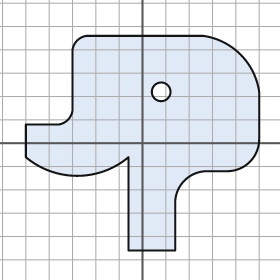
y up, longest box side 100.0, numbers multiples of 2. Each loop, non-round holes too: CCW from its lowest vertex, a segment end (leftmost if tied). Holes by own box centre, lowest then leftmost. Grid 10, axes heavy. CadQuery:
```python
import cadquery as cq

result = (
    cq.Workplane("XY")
    .moveTo(-6.0, -46.0)
    .lineTo(14.0, -46.0)
    .lineTo(14.0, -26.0)
    .threePointArc((18.0, -16.0), (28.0, -12.0))
    .lineTo(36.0, -12.0)
    .threePointArc((46.0, -8.0), (50.0, 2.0))
    .lineTo(50.0, 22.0)
    .threePointArc((42.0, 38.0), (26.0, 46.0))
    .lineTo(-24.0, 46.0)
    .threePointArc((-28.0, 44.0), (-30.0, 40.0))
    .lineTo(-30.0, 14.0)
    .threePointArc((-32.0, 10.0), (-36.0, 8.0))
    .lineTo(-50.0, 8.0)
    .lineTo(-50.0, -6.0)
    .threePointArc((-28.0, -14.0), (-6.0, -6.0))
    .close()
    .moveTo(8.0, 22.0)
    .circle(4.0)
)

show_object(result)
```